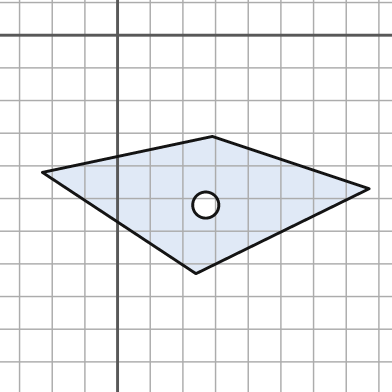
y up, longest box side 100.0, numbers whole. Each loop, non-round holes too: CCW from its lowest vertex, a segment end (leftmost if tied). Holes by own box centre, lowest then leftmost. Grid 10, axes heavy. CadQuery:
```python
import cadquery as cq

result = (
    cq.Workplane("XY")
    .moveTo(24.0, -73.0)
    .lineTo(77.0, -47.0)
    .lineTo(29.0, -31.0)
    .lineTo(-23.0, -42.0)
    .close()
    .moveTo(27.0, -52.0)
    .circle(4.0)
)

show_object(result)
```